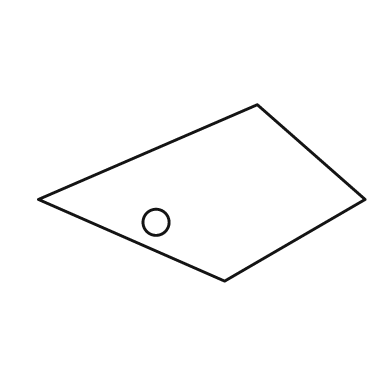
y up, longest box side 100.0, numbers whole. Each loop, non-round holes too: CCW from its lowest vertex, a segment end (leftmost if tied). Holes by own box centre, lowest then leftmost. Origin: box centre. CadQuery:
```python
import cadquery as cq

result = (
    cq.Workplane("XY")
    .moveTo(7.0, -27.0)
    .lineTo(50.0, -2.0)
    .lineTo(17.0, 27.0)
    .lineTo(-50.0, -2.0)
    .close()
    .moveTo(-14.0, -9.0)
    .circle(4.0)
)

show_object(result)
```